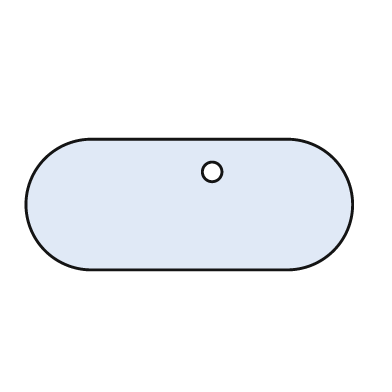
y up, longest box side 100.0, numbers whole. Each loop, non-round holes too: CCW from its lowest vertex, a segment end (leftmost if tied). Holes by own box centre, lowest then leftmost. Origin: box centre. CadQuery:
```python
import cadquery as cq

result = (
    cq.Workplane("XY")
    .moveTo(-30.0, -20.0)
    .lineTo(30.0, -20.0)
    .threePointArc((50.0, 0.0), (30.0, 20.0))
    .lineTo(-30.0, 20.0)
    .threePointArc((-50.0, 0.0), (-30.0, -20.0))
    .close()
    .moveTo(7.0, 10.0)
    .circle(3.0)
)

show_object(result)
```